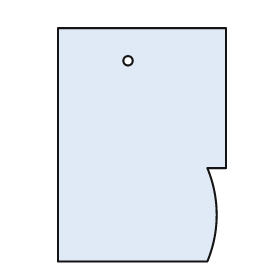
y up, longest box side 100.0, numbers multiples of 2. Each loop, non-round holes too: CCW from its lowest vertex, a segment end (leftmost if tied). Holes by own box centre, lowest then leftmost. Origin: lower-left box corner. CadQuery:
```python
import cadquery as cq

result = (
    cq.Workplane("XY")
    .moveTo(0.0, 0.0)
    .lineTo(64.0, 0.0)
    .threePointArc((68.0, 20.0), (64.0, 40.0))
    .lineTo(72.0, 40.0)
    .lineTo(72.0, 100.0)
    .lineTo(0.0, 100.0)
    .close()
    .moveTo(30.0, 86.0)
    .circle(2.0)
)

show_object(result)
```